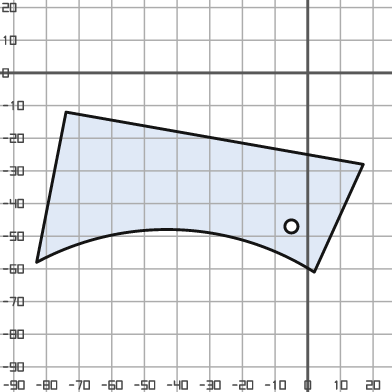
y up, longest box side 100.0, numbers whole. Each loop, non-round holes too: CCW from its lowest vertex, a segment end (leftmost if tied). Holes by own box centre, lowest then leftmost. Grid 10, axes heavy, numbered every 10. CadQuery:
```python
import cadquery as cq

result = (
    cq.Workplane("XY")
    .moveTo(2.0, -61.0)
    .lineTo(17.0, -28.0)
    .lineTo(-74.0, -12.0)
    .lineTo(-83.0, -58.0)
    .threePointArc((-40.0, -48.0), (2.0, -61.0))
    .close()
    .moveTo(-5.0, -47.0)
    .circle(2.0)
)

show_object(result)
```